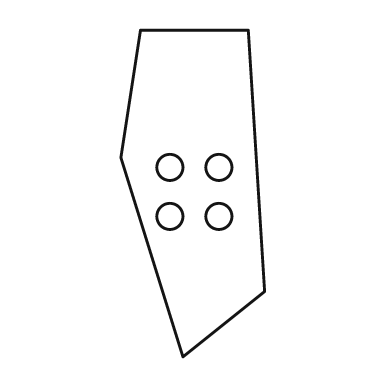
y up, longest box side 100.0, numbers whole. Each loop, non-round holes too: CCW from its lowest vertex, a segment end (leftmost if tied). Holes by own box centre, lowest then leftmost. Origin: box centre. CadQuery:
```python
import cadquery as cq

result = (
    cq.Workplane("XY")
    .moveTo(-3.0, -50.0)
    .lineTo(22.0, -30.0)
    .lineTo(17.0, 50.0)
    .lineTo(-16.0, 50.0)
    .lineTo(-22.0, 11.0)
    .close()
    .moveTo(-7.0, -7.0)
    .circle(4.0)
    .moveTo(8.0, -7.0)
    .circle(4.0)
    .moveTo(-7.0, 8.0)
    .circle(4.0)
    .moveTo(8.0, 8.0)
    .circle(4.0)
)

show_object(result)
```